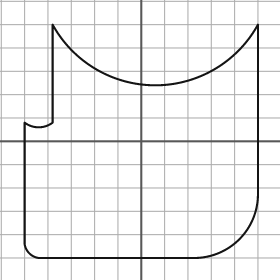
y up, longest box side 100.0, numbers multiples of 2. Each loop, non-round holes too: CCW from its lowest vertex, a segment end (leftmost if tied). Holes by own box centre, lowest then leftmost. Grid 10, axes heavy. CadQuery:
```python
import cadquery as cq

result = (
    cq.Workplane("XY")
    .moveTo(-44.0, -50.0)
    .lineTo(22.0, -50.0)
    .threePointArc((42.0, -42.0), (50.0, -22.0))
    .lineTo(50.0, 50.0)
    .threePointArc((6.0, 24.0), (-38.0, 50.0))
    .lineTo(-38.0, 8.0)
    .threePointArc((-44.0, 6.0), (-50.0, 8.0))
    .lineTo(-50.0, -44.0)
    .threePointArc((-48.0, -48.0), (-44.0, -50.0))
    .close()
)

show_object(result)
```